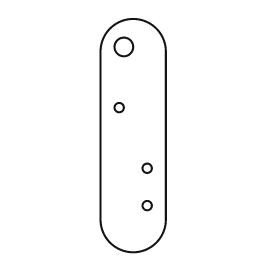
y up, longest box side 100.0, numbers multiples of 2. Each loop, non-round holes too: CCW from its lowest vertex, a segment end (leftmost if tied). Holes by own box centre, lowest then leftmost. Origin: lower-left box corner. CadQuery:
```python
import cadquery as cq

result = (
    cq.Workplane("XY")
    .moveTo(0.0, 14.0)
    .threePointArc((14.0, 0.0), (28.0, 14.0))
    .lineTo(28.0, 86.0)
    .threePointArc((14.0, 100.0), (0.0, 86.0))
    .close()
    .moveTo(20.0, 20.0)
    .circle(2.0)
    .moveTo(20.0, 36.0)
    .circle(2.0)
    .moveTo(8.0, 62.0)
    .circle(2.0)
    .moveTo(10.0, 88.0)
    .circle(4.0)
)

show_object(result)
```